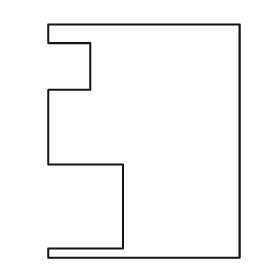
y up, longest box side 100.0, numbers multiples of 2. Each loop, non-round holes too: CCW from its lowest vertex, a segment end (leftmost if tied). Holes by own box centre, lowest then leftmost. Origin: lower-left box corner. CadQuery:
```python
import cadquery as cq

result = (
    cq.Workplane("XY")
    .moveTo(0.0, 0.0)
    .lineTo(82.0, 0.0)
    .lineTo(82.0, 100.0)
    .lineTo(0.0, 100.0)
    .lineTo(0.0, 92.0)
    .lineTo(18.0, 92.0)
    .lineTo(18.0, 72.0)
    .lineTo(0.0, 72.0)
    .lineTo(0.0, 40.0)
    .lineTo(32.0, 40.0)
    .lineTo(32.0, 4.0)
    .lineTo(0.0, 4.0)
    .close()
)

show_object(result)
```